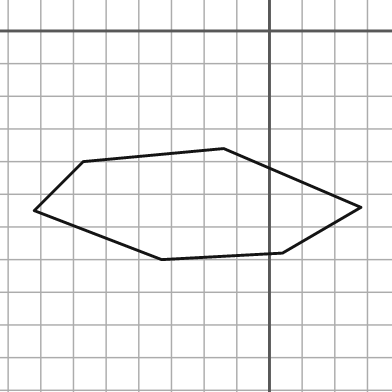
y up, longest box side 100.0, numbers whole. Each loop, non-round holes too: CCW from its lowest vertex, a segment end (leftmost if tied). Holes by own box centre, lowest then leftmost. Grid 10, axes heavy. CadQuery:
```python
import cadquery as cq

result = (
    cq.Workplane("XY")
    .moveTo(-33.0, -70.0)
    .lineTo(4.0, -68.0)
    .lineTo(28.0, -54.0)
    .lineTo(-14.0, -36.0)
    .lineTo(-57.0, -40.0)
    .lineTo(-72.0, -55.0)
    .close()
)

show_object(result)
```